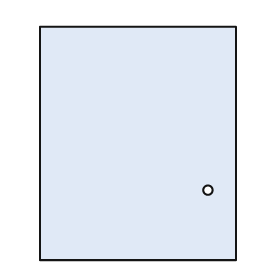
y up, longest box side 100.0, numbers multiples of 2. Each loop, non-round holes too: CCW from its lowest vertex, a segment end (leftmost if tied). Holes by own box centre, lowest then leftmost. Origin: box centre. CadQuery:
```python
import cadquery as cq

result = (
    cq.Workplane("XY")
    .moveTo(-42.0, -50.0)
    .lineTo(42.0, -50.0)
    .lineTo(42.0, 50.0)
    .lineTo(-42.0, 50.0)
    .close()
    .moveTo(30.0, -20.0)
    .circle(2.0)
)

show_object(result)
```